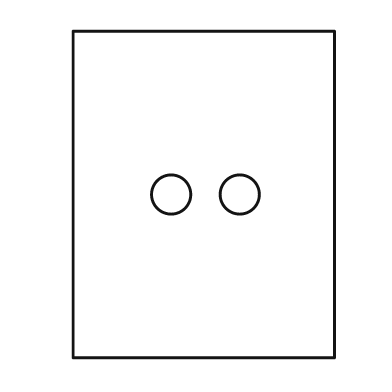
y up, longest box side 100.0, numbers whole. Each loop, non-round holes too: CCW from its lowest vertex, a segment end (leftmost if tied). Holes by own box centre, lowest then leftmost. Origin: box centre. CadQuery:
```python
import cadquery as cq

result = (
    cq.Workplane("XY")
    .moveTo(-40.0, -50.0)
    .lineTo(40.0, -50.0)
    .lineTo(40.0, 50.0)
    .lineTo(-40.0, 50.0)
    .close()
    .moveTo(-10.0, 0.0)
    .circle(6.0)
    .moveTo(11.0, 0.0)
    .circle(6.0)
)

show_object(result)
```